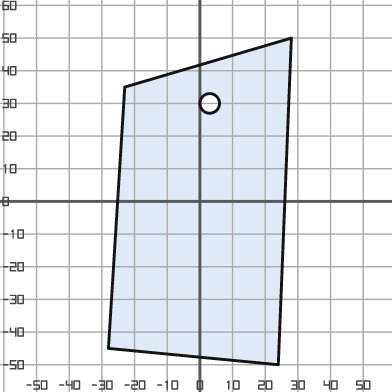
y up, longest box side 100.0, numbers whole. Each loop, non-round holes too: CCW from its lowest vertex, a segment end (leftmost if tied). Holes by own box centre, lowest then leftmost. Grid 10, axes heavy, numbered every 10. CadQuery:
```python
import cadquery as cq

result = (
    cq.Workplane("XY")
    .moveTo(24.0, -50.0)
    .lineTo(28.0, 50.0)
    .lineTo(-23.0, 35.0)
    .lineTo(-28.0, -45.0)
    .close()
    .moveTo(3.0, 30.0)
    .circle(3.0)
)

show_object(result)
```